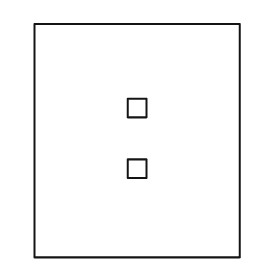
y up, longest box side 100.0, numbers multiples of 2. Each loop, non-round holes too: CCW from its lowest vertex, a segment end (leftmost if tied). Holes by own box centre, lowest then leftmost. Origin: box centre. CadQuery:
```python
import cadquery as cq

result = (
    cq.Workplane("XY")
    .moveTo(-44.0, -50.0)
    .lineTo(44.0, -50.0)
    .lineTo(44.0, 50.0)
    .lineTo(-44.0, 50.0)
    .close()
    .moveTo(-4.0, -16.0)
    .lineTo(4.0, -16.0)
    .lineTo(4.0, -8.0)
    .lineTo(-4.0, -8.0)
    .close()
    .moveTo(-4.0, 10.0)
    .lineTo(4.0, 10.0)
    .lineTo(4.0, 18.0)
    .lineTo(-4.0, 18.0)
    .close()
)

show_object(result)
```